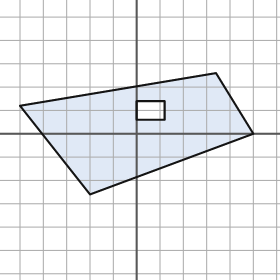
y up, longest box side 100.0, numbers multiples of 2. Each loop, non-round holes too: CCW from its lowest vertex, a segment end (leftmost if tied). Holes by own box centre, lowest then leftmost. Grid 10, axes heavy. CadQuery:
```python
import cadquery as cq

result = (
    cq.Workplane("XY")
    .moveTo(-20.0, -26.0)
    .lineTo(50.0, 0.0)
    .lineTo(34.0, 26.0)
    .lineTo(-50.0, 12.0)
    .close()
    .moveTo(0.0, 6.0)
    .lineTo(12.0, 6.0)
    .lineTo(12.0, 14.0)
    .lineTo(0.0, 14.0)
    .close()
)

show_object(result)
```